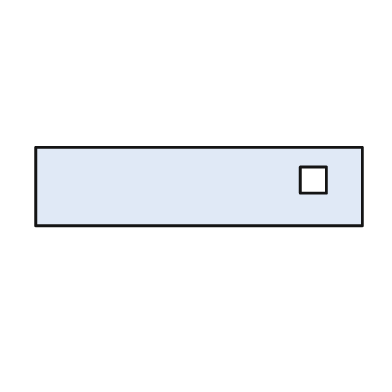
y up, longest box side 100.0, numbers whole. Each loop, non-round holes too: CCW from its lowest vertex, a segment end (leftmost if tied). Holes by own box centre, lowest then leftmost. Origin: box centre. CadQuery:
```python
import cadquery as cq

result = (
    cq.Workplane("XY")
    .moveTo(-50.0, -12.0)
    .lineTo(50.0, -12.0)
    .lineTo(50.0, 12.0)
    .lineTo(-50.0, 12.0)
    .close()
    .moveTo(31.0, -2.0)
    .lineTo(39.0, -2.0)
    .lineTo(39.0, 6.0)
    .lineTo(31.0, 6.0)
    .close()
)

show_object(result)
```